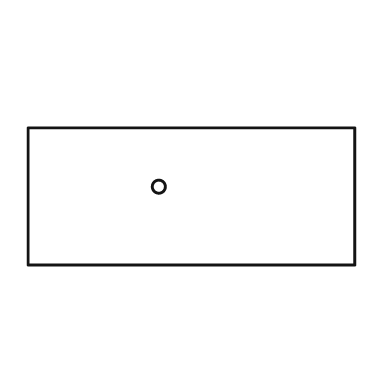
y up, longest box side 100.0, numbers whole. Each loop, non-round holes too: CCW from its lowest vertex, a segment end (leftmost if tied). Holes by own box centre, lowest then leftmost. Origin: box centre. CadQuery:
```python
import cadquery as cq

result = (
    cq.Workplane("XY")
    .moveTo(-50.0, -21.0)
    .lineTo(50.0, -21.0)
    .lineTo(50.0, 21.0)
    .lineTo(-50.0, 21.0)
    .close()
    .moveTo(-10.0, 3.0)
    .circle(2.0)
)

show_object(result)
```